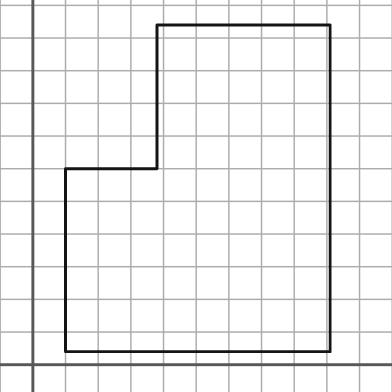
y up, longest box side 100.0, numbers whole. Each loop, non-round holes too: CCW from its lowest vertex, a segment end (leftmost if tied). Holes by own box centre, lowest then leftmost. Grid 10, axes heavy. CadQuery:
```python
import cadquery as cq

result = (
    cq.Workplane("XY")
    .moveTo(10.0, 4.0)
    .lineTo(91.0, 4.0)
    .lineTo(91.0, 104.0)
    .lineTo(38.0, 104.0)
    .lineTo(38.0, 60.0)
    .lineTo(10.0, 60.0)
    .close()
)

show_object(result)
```